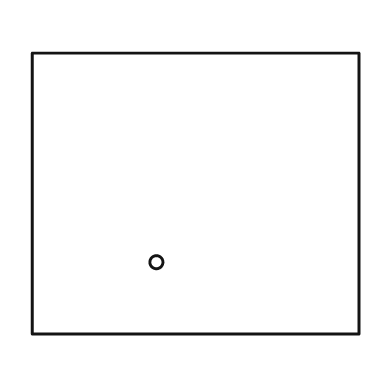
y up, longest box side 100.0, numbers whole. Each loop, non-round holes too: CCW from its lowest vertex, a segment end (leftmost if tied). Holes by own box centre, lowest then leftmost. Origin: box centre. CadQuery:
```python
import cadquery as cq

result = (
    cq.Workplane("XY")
    .moveTo(-50.0, -43.0)
    .lineTo(50.0, -43.0)
    .lineTo(50.0, 43.0)
    .lineTo(-50.0, 43.0)
    .close()
    .moveTo(-12.0, -21.0)
    .circle(2.0)
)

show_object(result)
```